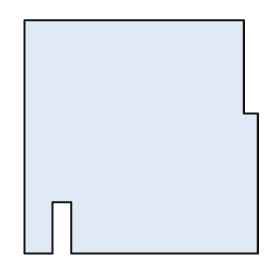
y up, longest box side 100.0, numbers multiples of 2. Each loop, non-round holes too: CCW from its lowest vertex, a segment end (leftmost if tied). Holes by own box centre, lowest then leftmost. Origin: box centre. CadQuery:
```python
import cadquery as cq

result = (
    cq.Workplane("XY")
    .moveTo(-50.0, -50.0)
    .lineTo(-38.0, -50.0)
    .lineTo(-38.0, -28.0)
    .lineTo(-30.0, -28.0)
    .lineTo(-30.0, -50.0)
    .lineTo(50.0, -50.0)
    .lineTo(50.0, 10.0)
    .lineTo(44.0, 10.0)
    .lineTo(44.0, 50.0)
    .lineTo(-50.0, 50.0)
    .close()
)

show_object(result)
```